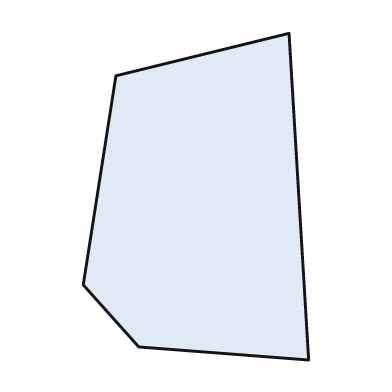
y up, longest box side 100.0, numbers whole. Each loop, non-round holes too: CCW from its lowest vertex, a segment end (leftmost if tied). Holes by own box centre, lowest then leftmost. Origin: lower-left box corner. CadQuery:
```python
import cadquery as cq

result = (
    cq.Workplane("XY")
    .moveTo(69.0, 0.0)
    .lineTo(63.0, 100.0)
    .lineTo(10.0, 87.0)
    .lineTo(0.0, 23.0)
    .lineTo(17.0, 4.0)
    .close()
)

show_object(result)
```